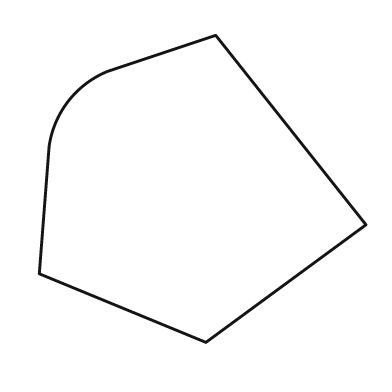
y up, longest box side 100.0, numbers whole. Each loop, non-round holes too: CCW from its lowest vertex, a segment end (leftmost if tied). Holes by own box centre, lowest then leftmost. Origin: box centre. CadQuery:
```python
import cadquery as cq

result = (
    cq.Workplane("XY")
    .moveTo(1.0, -47.0)
    .lineTo(50.0, -11.0)
    .lineTo(4.0, 47.0)
    .lineTo(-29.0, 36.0)
    .threePointArc((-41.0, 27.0), (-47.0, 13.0))
    .lineTo(-50.0, -26.0)
    .close()
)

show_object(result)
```